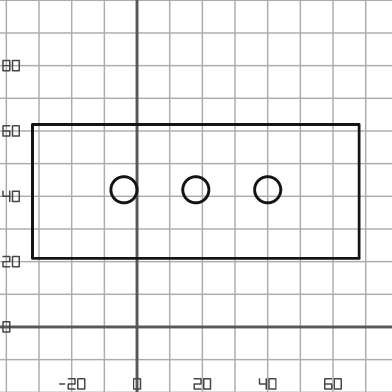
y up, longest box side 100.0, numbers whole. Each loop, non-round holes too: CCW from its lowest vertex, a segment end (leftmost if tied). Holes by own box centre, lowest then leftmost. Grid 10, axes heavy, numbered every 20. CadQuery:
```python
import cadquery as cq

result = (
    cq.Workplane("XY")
    .moveTo(-32.0, 21.0)
    .lineTo(68.0, 21.0)
    .lineTo(68.0, 62.0)
    .lineTo(-32.0, 62.0)
    .close()
    .moveTo(-4.0, 42.0)
    .circle(4.0)
    .moveTo(18.0, 42.0)
    .circle(4.0)
    .moveTo(40.0, 42.0)
    .circle(4.0)
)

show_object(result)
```